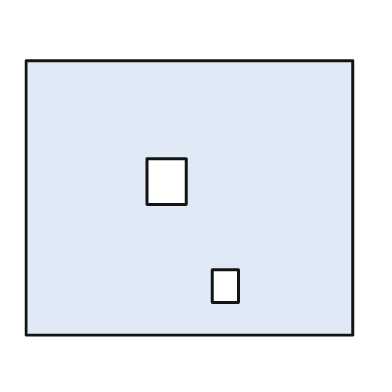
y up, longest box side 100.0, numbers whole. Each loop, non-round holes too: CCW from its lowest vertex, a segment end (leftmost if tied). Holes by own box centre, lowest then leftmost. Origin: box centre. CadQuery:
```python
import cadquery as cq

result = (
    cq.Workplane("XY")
    .moveTo(-50.0, -42.0)
    .lineTo(50.0, -42.0)
    .lineTo(50.0, 42.0)
    .lineTo(-50.0, 42.0)
    .close()
    .moveTo(7.0, -32.0)
    .lineTo(15.0, -32.0)
    .lineTo(15.0, -22.0)
    .lineTo(7.0, -22.0)
    .close()
    .moveTo(-13.0, -2.0)
    .lineTo(-1.0, -2.0)
    .lineTo(-1.0, 12.0)
    .lineTo(-13.0, 12.0)
    .close()
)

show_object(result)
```